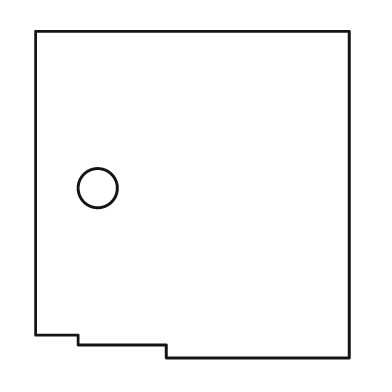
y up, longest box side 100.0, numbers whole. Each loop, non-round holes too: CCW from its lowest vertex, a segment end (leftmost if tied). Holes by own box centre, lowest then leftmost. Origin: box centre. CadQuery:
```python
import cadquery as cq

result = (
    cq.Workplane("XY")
    .moveTo(-8.0, -50.0)
    .lineTo(48.0, -50.0)
    .lineTo(48.0, 50.0)
    .lineTo(-48.0, 50.0)
    .lineTo(-48.0, -43.0)
    .lineTo(-35.0, -43.0)
    .lineTo(-35.0, -46.0)
    .lineTo(-8.0, -46.0)
    .close()
    .moveTo(-29.0, 2.0)
    .circle(6.0)
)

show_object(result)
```